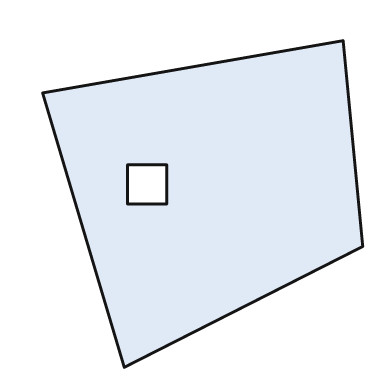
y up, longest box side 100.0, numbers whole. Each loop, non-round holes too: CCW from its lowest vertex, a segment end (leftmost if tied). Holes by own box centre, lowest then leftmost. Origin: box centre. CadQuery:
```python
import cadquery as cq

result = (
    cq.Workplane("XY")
    .moveTo(-24.0, -50.0)
    .lineTo(49.0, -13.0)
    .lineTo(43.0, 50.0)
    .lineTo(-49.0, 34.0)
    .close()
    .moveTo(-23.0, 0.0)
    .lineTo(-11.0, 0.0)
    .lineTo(-11.0, 12.0)
    .lineTo(-23.0, 12.0)
    .close()
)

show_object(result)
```